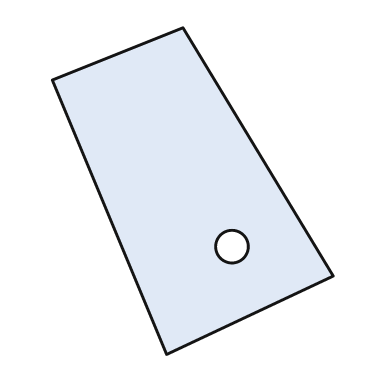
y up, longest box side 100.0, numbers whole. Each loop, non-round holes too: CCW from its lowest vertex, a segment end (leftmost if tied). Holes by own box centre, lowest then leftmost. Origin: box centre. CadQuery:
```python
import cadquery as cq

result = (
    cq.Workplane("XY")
    .moveTo(-8.0, -50.0)
    .lineTo(43.0, -26.0)
    .lineTo(-3.0, 50.0)
    .lineTo(-43.0, 34.0)
    .close()
    .moveTo(12.0, -17.0)
    .circle(5.0)
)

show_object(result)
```